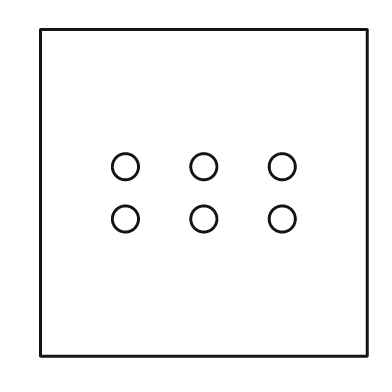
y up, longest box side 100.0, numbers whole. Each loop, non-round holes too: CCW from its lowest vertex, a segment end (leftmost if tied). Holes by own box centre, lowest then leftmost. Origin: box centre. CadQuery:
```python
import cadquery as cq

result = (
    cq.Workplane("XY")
    .moveTo(-50.0, -50.0)
    .lineTo(50.0, -50.0)
    .lineTo(50.0, 50.0)
    .lineTo(-50.0, 50.0)
    .close()
    .moveTo(-24.0, -8.0)
    .circle(4.0)
    .moveTo(0.0, -8.0)
    .circle(4.0)
    .moveTo(24.0, -8.0)
    .circle(4.0)
    .moveTo(-24.0, 8.0)
    .circle(4.0)
    .moveTo(0.0, 8.0)
    .circle(4.0)
    .moveTo(24.0, 8.0)
    .circle(4.0)
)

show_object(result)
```